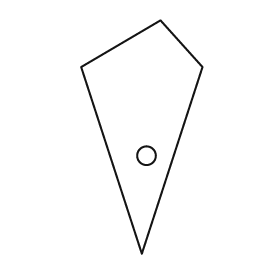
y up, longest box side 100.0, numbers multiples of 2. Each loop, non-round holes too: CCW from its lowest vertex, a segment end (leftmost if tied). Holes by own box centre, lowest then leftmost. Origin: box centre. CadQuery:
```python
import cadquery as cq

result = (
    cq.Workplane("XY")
    .moveTo(0.0, -50.0)
    .lineTo(26.0, 30.0)
    .lineTo(8.0, 50.0)
    .lineTo(-26.0, 30.0)
    .close()
    .moveTo(2.0, -8.0)
    .circle(4.0)
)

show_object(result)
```